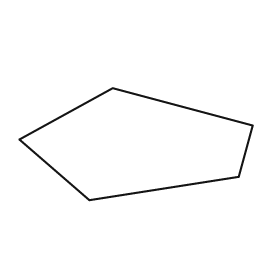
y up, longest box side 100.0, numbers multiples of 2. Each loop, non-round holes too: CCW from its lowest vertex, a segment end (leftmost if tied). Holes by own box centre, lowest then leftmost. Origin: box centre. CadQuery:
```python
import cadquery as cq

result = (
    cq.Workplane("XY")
    .moveTo(-20.0, -24.0)
    .lineTo(44.0, -14.0)
    .lineTo(50.0, 8.0)
    .lineTo(-10.0, 24.0)
    .lineTo(-50.0, 2.0)
    .close()
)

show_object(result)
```